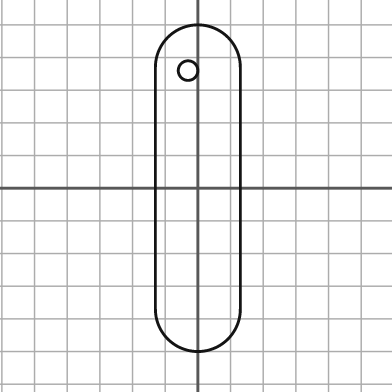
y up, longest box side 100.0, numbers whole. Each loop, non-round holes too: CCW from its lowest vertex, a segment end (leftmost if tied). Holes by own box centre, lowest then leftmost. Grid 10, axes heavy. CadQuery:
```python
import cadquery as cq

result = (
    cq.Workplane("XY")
    .moveTo(-13.0, -37.0)
    .threePointArc((0.0, -50.0), (13.0, -37.0))
    .lineTo(13.0, 37.0)
    .threePointArc((0.0, 50.0), (-13.0, 37.0))
    .close()
    .moveTo(-3.0, 36.0)
    .circle(3.0)
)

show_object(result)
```